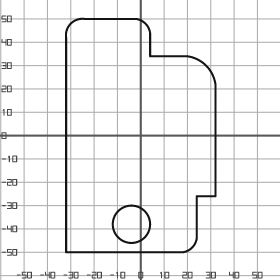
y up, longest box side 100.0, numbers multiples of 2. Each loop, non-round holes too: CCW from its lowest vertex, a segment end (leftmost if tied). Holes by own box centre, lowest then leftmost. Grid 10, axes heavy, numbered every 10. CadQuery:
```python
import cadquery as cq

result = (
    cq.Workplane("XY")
    .moveTo(-32.0, -50.0)
    .lineTo(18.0, -50.0)
    .threePointArc((22.0, -48.0), (24.0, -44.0))
    .lineTo(24.0, -26.0)
    .lineTo(32.0, -26.0)
    .lineTo(32.0, 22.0)
    .threePointArc((28.0, 30.0), (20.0, 34.0))
    .lineTo(4.0, 34.0)
    .lineTo(4.0, 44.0)
    .threePointArc((2.0, 48.0), (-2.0, 50.0))
    .lineTo(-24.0, 50.0)
    .threePointArc((-30.0, 48.0), (-32.0, 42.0))
    .close()
    .moveTo(-4.0, -38.0)
    .circle(8.0)
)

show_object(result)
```